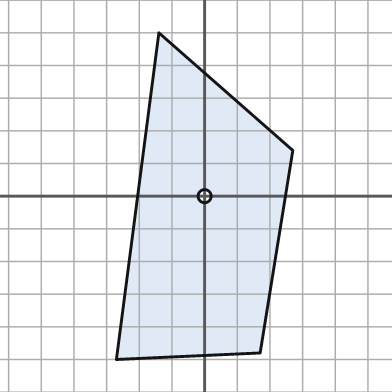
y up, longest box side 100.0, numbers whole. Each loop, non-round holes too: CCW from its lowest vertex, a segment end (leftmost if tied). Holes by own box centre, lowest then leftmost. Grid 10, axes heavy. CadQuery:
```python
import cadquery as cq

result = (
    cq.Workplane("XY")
    .moveTo(-27.0, -50.0)
    .lineTo(17.0, -48.0)
    .lineTo(27.0, 14.0)
    .lineTo(-14.0, 50.0)
    .close()
    .moveTo(0.0, 0.0)
    .circle(2.0)
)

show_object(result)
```